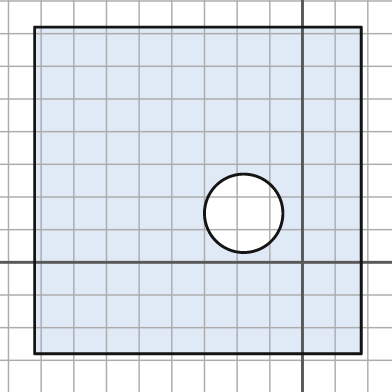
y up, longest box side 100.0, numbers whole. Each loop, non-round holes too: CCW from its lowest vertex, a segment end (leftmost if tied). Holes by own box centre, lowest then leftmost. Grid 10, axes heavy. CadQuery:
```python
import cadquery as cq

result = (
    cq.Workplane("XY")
    .moveTo(-82.0, -28.0)
    .lineTo(18.0, -28.0)
    .lineTo(18.0, 72.0)
    .lineTo(-82.0, 72.0)
    .close()
    .moveTo(-18.0, 15.0)
    .circle(12.0)
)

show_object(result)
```